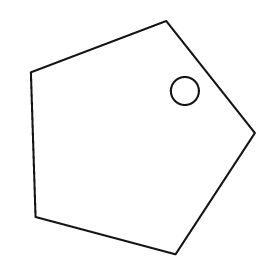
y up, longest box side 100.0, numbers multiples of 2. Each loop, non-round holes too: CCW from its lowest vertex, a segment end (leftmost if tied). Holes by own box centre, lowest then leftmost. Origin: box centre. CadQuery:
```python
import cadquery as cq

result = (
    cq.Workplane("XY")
    .moveTo(14.0, -50.0)
    .lineTo(48.0, 2.0)
    .lineTo(10.0, 50.0)
    .lineTo(-48.0, 28.0)
    .lineTo(-46.0, -34.0)
    .close()
    .moveTo(18.0, 20.0)
    .circle(6.0)
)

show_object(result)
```